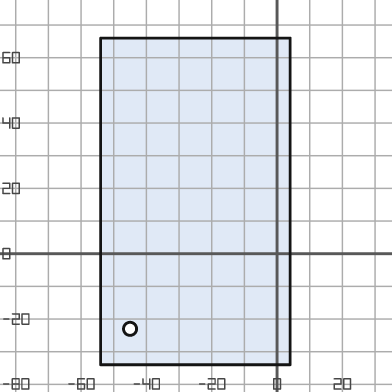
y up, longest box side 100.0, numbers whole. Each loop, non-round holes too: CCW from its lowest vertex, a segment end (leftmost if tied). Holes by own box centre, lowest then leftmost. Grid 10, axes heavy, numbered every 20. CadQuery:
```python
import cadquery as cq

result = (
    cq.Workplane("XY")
    .moveTo(-54.0, -34.0)
    .lineTo(4.0, -34.0)
    .lineTo(4.0, 66.0)
    .lineTo(-54.0, 66.0)
    .close()
    .moveTo(-45.0, -23.0)
    .circle(2.0)
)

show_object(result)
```